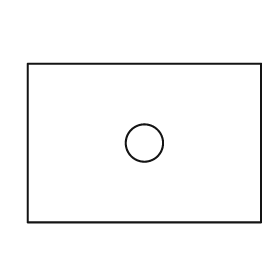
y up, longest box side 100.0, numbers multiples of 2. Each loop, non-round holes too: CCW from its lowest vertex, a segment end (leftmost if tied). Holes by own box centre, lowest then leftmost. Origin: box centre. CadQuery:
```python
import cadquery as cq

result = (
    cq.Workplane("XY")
    .moveTo(-50.0, -34.0)
    .lineTo(50.0, -34.0)
    .lineTo(50.0, 34.0)
    .lineTo(-50.0, 34.0)
    .close()
    .moveTo(0.0, 0.0)
    .circle(8.0)
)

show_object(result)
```